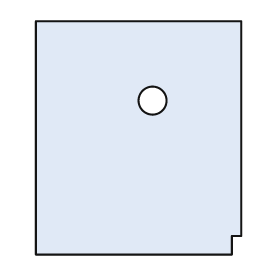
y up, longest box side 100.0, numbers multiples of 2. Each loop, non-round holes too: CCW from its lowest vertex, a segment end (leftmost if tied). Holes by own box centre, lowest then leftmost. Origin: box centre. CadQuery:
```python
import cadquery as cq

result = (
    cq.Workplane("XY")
    .moveTo(-44.0, -50.0)
    .lineTo(40.0, -50.0)
    .lineTo(40.0, -42.0)
    .lineTo(44.0, -42.0)
    .lineTo(44.0, 50.0)
    .lineTo(-44.0, 50.0)
    .close()
    .moveTo(6.0, 16.0)
    .circle(6.0)
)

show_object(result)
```